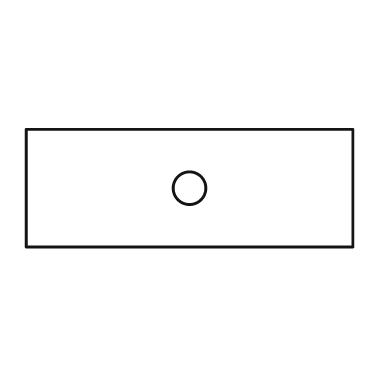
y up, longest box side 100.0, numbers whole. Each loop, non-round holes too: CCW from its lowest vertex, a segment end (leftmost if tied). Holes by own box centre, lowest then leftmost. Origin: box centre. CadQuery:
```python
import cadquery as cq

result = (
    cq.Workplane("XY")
    .moveTo(-50.0, -18.0)
    .lineTo(50.0, -18.0)
    .lineTo(50.0, 18.0)
    .lineTo(-50.0, 18.0)
    .close()
    .moveTo(0.0, 0.0)
    .circle(5.0)
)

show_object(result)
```